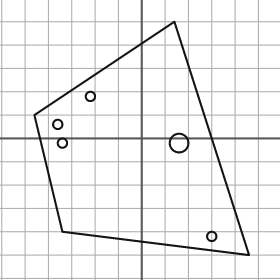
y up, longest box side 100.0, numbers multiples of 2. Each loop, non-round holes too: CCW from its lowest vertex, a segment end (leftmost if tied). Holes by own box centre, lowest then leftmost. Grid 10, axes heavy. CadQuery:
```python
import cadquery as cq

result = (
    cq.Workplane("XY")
    .moveTo(46.0, -50.0)
    .lineTo(14.0, 50.0)
    .lineTo(-46.0, 10.0)
    .lineTo(-34.0, -40.0)
    .close()
    .moveTo(30.0, -42.0)
    .circle(2.0)
    .moveTo(-34.0, -2.0)
    .circle(2.0)
    .moveTo(16.0, -2.0)
    .circle(4.0)
    .moveTo(-36.0, 6.0)
    .circle(2.0)
    .moveTo(-22.0, 18.0)
    .circle(2.0)
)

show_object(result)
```